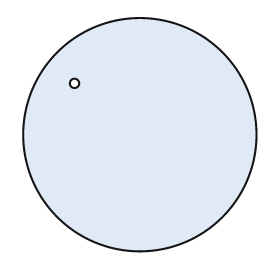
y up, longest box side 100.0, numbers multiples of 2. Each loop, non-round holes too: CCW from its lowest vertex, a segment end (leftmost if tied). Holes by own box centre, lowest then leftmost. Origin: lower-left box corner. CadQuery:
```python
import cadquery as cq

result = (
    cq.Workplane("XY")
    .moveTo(50.0, 50.0)
    .circle(50.0)
    .moveTo(22.0, 72.0)
    .circle(2.0)
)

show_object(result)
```